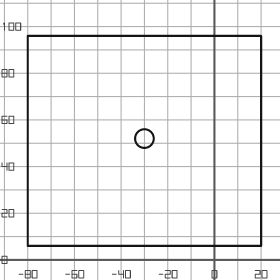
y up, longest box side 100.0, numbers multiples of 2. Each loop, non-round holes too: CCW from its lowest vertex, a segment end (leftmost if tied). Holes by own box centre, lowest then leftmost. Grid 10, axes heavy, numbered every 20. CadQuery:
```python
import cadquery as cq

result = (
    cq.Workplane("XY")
    .moveTo(-80.0, 6.0)
    .lineTo(20.0, 6.0)
    .lineTo(20.0, 96.0)
    .lineTo(-80.0, 96.0)
    .close()
    .moveTo(-30.0, 52.0)
    .circle(4.0)
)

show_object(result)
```